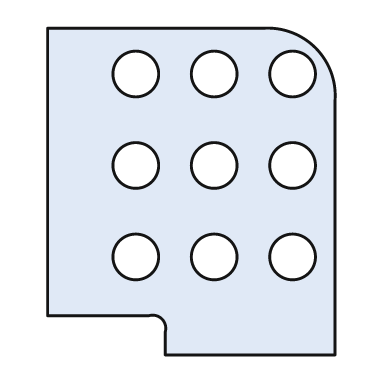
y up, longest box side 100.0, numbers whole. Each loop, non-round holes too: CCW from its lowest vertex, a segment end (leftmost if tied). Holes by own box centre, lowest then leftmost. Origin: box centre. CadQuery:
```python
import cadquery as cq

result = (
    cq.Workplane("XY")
    .moveTo(-8.0, -50.0)
    .lineTo(44.0, -50.0)
    .lineTo(44.0, 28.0)
    .threePointArc((38.0, 44.0), (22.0, 50.0))
    .lineTo(-44.0, 50.0)
    .lineTo(-44.0, -38.0)
    .lineTo(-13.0, -38.0)
    .threePointArc((-9.0, -39.0), (-8.0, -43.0))
    .close()
    .moveTo(-17.0, -20.0)
    .circle(7.0)
    .moveTo(7.0, -20.0)
    .circle(7.0)
    .moveTo(31.0, -20.0)
    .circle(7.0)
    .moveTo(-17.0, 8.0)
    .circle(7.0)
    .moveTo(7.0, 8.0)
    .circle(7.0)
    .moveTo(31.0, 8.0)
    .circle(7.0)
    .moveTo(-17.0, 36.0)
    .circle(7.0)
    .moveTo(7.0, 36.0)
    .circle(7.0)
    .moveTo(31.0, 36.0)
    .circle(7.0)
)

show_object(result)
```